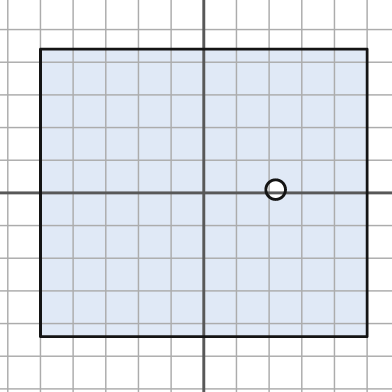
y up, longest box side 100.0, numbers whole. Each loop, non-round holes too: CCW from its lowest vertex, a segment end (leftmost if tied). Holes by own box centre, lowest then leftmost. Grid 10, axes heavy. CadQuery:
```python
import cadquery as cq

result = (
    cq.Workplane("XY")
    .moveTo(-50.0, -44.0)
    .lineTo(50.0, -44.0)
    .lineTo(50.0, 44.0)
    .lineTo(-50.0, 44.0)
    .close()
    .moveTo(22.0, 1.0)
    .circle(3.0)
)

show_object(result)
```